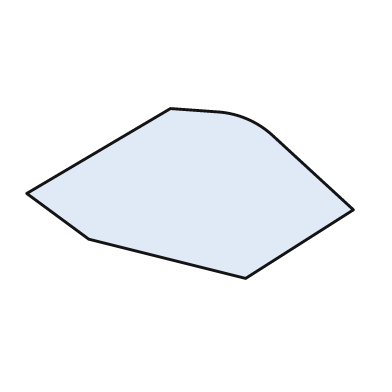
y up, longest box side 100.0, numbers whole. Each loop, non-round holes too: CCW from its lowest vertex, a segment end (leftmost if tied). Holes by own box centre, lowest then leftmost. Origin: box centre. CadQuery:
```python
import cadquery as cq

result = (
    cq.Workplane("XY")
    .moveTo(17.0, -26.0)
    .lineTo(50.0, -5.0)
    .lineTo(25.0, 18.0)
    .threePointArc((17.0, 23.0), (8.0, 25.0))
    .lineTo(-6.0, 26.0)
    .lineTo(-50.0, 0.0)
    .lineTo(-31.0, -14.0)
    .close()
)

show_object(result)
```